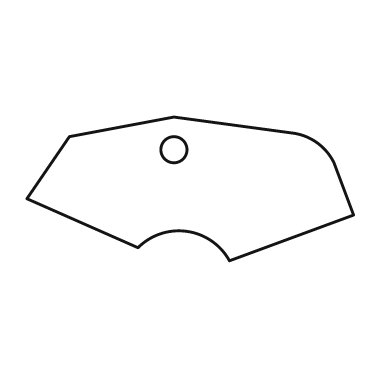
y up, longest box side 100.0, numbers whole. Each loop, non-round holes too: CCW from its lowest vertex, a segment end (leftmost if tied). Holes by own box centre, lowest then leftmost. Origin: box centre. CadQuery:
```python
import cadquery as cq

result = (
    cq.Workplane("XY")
    .moveTo(12.0, -22.0)
    .lineTo(50.0, -8.0)
    .lineTo(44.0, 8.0)
    .threePointArc((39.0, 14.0), (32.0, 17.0))
    .lineTo(-5.0, 22.0)
    .lineTo(-37.0, 16.0)
    .lineTo(-50.0, -3.0)
    .lineTo(-16.0, -18.0)
    .threePointArc((-1.0, -13.0), (12.0, -22.0))
    .close()
    .moveTo(-5.0, 12.0)
    .circle(4.0)
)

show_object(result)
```